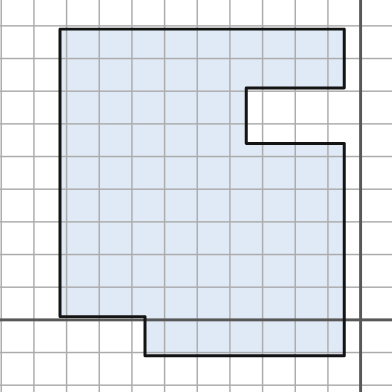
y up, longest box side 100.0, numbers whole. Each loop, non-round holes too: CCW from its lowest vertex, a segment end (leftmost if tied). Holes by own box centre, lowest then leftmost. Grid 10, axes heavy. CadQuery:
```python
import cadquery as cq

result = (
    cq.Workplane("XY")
    .moveTo(-66.0, -11.0)
    .lineTo(-5.0, -11.0)
    .lineTo(-5.0, 54.0)
    .lineTo(-35.0, 54.0)
    .lineTo(-35.0, 71.0)
    .lineTo(-5.0, 71.0)
    .lineTo(-5.0, 89.0)
    .lineTo(-92.0, 89.0)
    .lineTo(-92.0, 1.0)
    .lineTo(-66.0, 1.0)
    .close()
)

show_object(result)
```